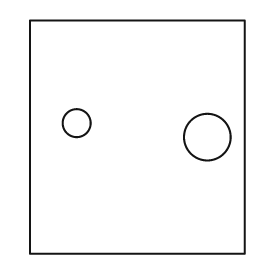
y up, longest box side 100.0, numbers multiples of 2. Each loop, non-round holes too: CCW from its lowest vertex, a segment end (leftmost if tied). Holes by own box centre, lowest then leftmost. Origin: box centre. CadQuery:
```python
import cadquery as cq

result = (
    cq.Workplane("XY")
    .moveTo(-46.0, -50.0)
    .lineTo(46.0, -50.0)
    .lineTo(46.0, 50.0)
    .lineTo(-46.0, 50.0)
    .close()
    .moveTo(30.0, 0.0)
    .circle(10.0)
    .moveTo(-26.0, 6.0)
    .circle(6.0)
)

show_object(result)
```